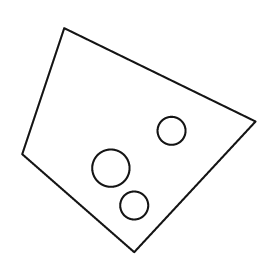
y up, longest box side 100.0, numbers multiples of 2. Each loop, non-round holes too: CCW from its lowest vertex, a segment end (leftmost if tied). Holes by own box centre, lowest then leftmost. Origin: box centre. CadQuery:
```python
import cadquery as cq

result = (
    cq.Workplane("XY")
    .moveTo(-2.0, -48.0)
    .lineTo(50.0, 8.0)
    .lineTo(-32.0, 48.0)
    .lineTo(-50.0, -6.0)
    .close()
    .moveTo(-2.0, -28.0)
    .circle(6.0)
    .moveTo(-12.0, -12.0)
    .circle(8.0)
    .moveTo(14.0, 4.0)
    .circle(6.0)
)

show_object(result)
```